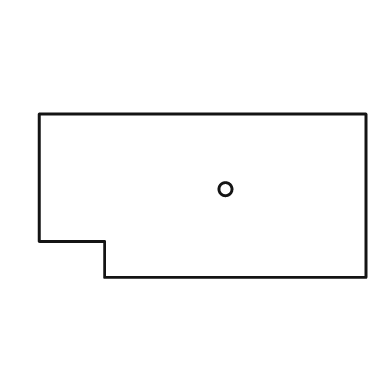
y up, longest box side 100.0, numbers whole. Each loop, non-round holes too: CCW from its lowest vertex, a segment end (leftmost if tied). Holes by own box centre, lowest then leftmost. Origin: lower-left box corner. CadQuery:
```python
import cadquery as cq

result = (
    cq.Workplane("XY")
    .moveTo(20.0, 0.0)
    .lineTo(100.0, 0.0)
    .lineTo(100.0, 50.0)
    .lineTo(0.0, 50.0)
    .lineTo(0.0, 11.0)
    .lineTo(20.0, 11.0)
    .close()
    .moveTo(57.0, 27.0)
    .circle(2.0)
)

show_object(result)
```